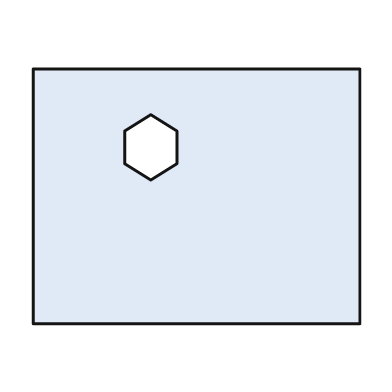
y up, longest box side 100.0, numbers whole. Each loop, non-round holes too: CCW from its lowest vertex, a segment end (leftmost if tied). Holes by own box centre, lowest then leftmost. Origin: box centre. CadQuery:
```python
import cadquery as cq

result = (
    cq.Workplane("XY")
    .moveTo(-50.0, -39.0)
    .lineTo(50.0, -39.0)
    .lineTo(50.0, 39.0)
    .lineTo(-50.0, 39.0)
    .close()
    .moveTo(-14.0, 5.0)
    .lineTo(-6.0, 10.0)
    .lineTo(-6.0, 20.0)
    .lineTo(-14.0, 25.0)
    .lineTo(-22.0, 20.0)
    .lineTo(-22.0, 10.0)
    .close()
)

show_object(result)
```